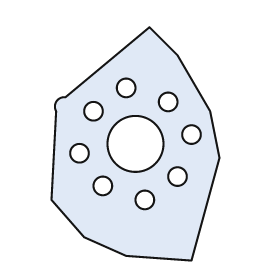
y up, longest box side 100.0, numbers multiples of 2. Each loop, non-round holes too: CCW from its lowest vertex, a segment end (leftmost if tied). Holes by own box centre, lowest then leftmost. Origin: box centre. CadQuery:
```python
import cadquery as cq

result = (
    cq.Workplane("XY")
    .moveTo(24.0, -50.0)
    .lineTo(36.0, -6.0)
    .lineTo(32.0, 14.0)
    .lineTo(18.0, 38.0)
    .lineTo(6.0, 50.0)
    .lineTo(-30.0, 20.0)
    .threePointArc((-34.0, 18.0), (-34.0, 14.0))
    .lineTo(-36.0, -24.0)
    .lineTo(-22.0, -40.0)
    .lineTo(-4.0, -48.0)
    .close()
    .moveTo(4.0, -24.0)
    .circle(4.0)
    .moveTo(-14.0, -18.0)
    .circle(4.0)
    .moveTo(18.0, -14.0)
    .circle(4.0)
    .moveTo(-24.0, -4.0)
    .circle(4.0)
    .moveTo(0.0, 0.0)
    .circle(12.0)
    .moveTo(24.0, 4.0)
    .circle(4.0)
    .moveTo(-18.0, 14.0)
    .circle(4.0)
    .moveTo(14.0, 18.0)
    .circle(4.0)
    .moveTo(-4.0, 24.0)
    .circle(4.0)
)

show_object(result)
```